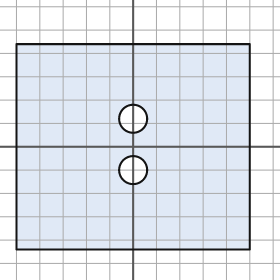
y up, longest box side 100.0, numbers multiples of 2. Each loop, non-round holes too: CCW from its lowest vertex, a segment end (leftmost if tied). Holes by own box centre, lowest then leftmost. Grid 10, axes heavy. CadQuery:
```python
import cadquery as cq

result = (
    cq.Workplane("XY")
    .moveTo(-50.0, -44.0)
    .lineTo(50.0, -44.0)
    .lineTo(50.0, 44.0)
    .lineTo(-50.0, 44.0)
    .close()
    .moveTo(0.0, -10.0)
    .circle(6.0)
    .moveTo(0.0, 12.0)
    .circle(6.0)
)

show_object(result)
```